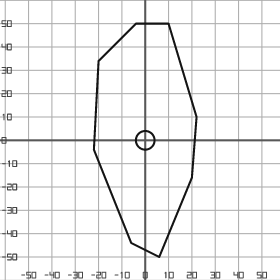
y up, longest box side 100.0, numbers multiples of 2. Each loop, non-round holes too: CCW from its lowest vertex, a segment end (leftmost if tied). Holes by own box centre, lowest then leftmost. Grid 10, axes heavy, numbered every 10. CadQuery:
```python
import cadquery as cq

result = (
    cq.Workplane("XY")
    .moveTo(6.0, -50.0)
    .lineTo(20.0, -16.0)
    .lineTo(22.0, 10.0)
    .lineTo(10.0, 50.0)
    .lineTo(-4.0, 50.0)
    .lineTo(-20.0, 34.0)
    .lineTo(-22.0, -4.0)
    .lineTo(-6.0, -44.0)
    .close()
    .moveTo(0.0, 0.0)
    .circle(4.0)
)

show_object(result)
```